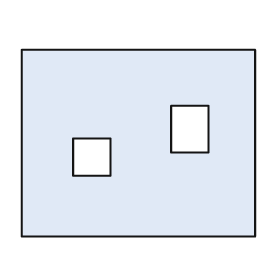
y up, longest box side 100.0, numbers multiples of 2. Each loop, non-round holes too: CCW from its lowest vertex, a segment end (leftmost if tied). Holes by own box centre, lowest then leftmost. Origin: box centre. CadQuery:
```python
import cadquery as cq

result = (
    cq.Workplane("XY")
    .moveTo(-50.0, -40.0)
    .lineTo(50.0, -40.0)
    .lineTo(50.0, 40.0)
    .lineTo(-50.0, 40.0)
    .close()
    .moveTo(-28.0, -14.0)
    .lineTo(-12.0, -14.0)
    .lineTo(-12.0, 2.0)
    .lineTo(-28.0, 2.0)
    .close()
    .moveTo(14.0, -4.0)
    .lineTo(30.0, -4.0)
    .lineTo(30.0, 16.0)
    .lineTo(14.0, 16.0)
    .close()
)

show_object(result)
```